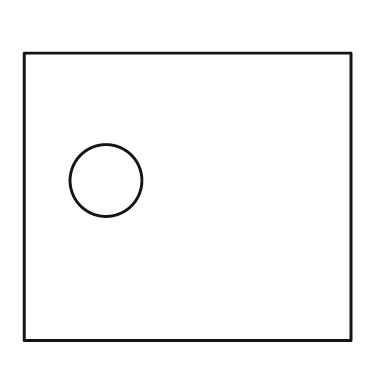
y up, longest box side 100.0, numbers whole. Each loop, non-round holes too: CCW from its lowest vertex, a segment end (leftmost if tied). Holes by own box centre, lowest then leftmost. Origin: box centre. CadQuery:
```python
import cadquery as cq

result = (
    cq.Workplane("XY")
    .moveTo(-50.0, -44.0)
    .lineTo(50.0, -44.0)
    .lineTo(50.0, 44.0)
    .lineTo(-50.0, 44.0)
    .close()
    .moveTo(-25.0, 5.0)
    .circle(11.0)
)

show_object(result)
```